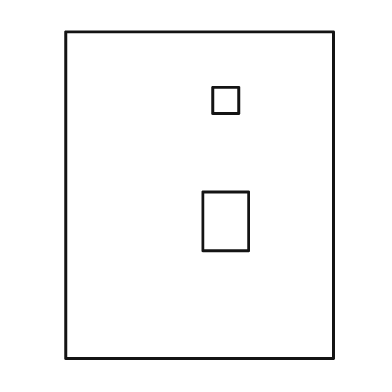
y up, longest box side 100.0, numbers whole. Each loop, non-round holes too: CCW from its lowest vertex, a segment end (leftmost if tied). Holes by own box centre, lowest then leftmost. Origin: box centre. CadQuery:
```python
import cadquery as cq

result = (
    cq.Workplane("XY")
    .moveTo(-41.0, -50.0)
    .lineTo(41.0, -50.0)
    .lineTo(41.0, 50.0)
    .lineTo(-41.0, 50.0)
    .close()
    .moveTo(1.0, -17.0)
    .lineTo(15.0, -17.0)
    .lineTo(15.0, 1.0)
    .lineTo(1.0, 1.0)
    .close()
    .moveTo(4.0, 25.0)
    .lineTo(12.0, 25.0)
    .lineTo(12.0, 33.0)
    .lineTo(4.0, 33.0)
    .close()
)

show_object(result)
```